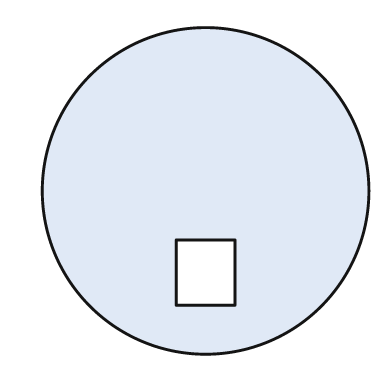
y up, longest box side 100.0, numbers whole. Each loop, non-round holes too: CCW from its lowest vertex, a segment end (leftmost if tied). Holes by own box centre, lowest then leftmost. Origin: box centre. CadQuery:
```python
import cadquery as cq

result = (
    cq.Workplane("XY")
    .moveTo(0.0, 0.0)
    .circle(50.0)
    .moveTo(-9.0, -35.0)
    .lineTo(9.0, -35.0)
    .lineTo(9.0, -15.0)
    .lineTo(-9.0, -15.0)
    .close()
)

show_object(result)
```